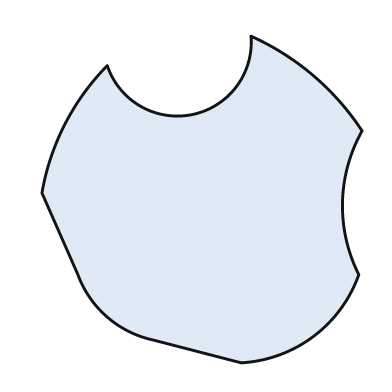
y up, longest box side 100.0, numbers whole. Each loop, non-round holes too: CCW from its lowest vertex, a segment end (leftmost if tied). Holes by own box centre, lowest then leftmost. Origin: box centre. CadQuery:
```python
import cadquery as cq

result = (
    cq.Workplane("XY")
    .moveTo(12.0, -50.0)
    .threePointArc((34.0, -42.0), (48.0, -23.0))
    .threePointArc((43.0, -1.0), (49.0, 21.0))
    .threePointArc((34.0, 38.0), (15.0, 50.0))
    .threePointArc((-3.0, 26.0), (-29.0, 41.0))
    .threePointArc((-42.0, 23.0), (-49.0, 2.0))
    .lineTo(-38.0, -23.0)
    .threePointArc((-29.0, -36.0), (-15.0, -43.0))
    .close()
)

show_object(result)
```